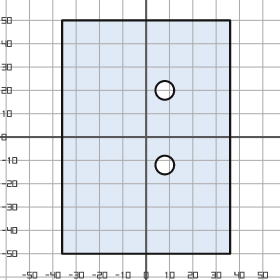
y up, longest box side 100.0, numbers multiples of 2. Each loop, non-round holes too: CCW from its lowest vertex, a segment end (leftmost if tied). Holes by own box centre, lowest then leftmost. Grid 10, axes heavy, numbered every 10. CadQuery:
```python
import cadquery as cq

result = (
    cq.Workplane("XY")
    .moveTo(-36.0, -50.0)
    .lineTo(36.0, -50.0)
    .lineTo(36.0, 50.0)
    .lineTo(-36.0, 50.0)
    .close()
    .moveTo(8.0, -12.0)
    .circle(4.0)
    .moveTo(8.0, 20.0)
    .circle(4.0)
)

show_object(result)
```